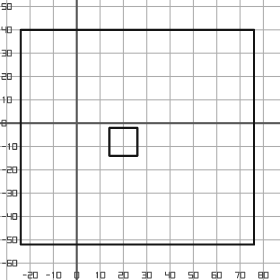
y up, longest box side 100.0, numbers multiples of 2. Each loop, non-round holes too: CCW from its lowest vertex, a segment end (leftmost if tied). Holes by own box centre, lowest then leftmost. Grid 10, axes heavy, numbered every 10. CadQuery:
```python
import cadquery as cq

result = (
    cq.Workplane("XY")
    .moveTo(-24.0, -52.0)
    .lineTo(76.0, -52.0)
    .lineTo(76.0, 40.0)
    .lineTo(-24.0, 40.0)
    .close()
    .moveTo(14.0, -14.0)
    .lineTo(26.0, -14.0)
    .lineTo(26.0, -2.0)
    .lineTo(14.0, -2.0)
    .close()
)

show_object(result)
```